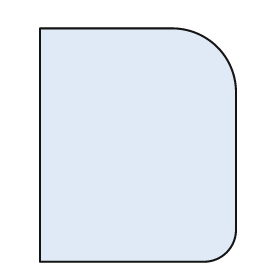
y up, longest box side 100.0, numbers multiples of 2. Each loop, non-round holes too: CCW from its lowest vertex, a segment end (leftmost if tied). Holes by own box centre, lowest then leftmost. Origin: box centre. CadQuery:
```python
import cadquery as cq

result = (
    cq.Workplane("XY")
    .moveTo(-42.0, -50.0)
    .lineTo(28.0, -50.0)
    .threePointArc((38.0, -46.0), (42.0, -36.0))
    .lineTo(42.0, 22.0)
    .threePointArc((34.0, 42.0), (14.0, 50.0))
    .lineTo(-42.0, 50.0)
    .close()
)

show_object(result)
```